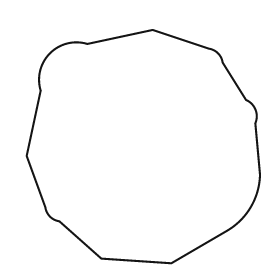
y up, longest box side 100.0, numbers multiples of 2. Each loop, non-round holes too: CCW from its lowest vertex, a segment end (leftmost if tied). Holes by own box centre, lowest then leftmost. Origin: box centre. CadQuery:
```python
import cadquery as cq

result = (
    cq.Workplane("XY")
    .moveTo(12.0, -50.0)
    .lineTo(36.0, -36.0)
    .threePointArc((46.0, -26.0), (50.0, -12.0))
    .lineTo(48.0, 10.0)
    .threePointArc((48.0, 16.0), (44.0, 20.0))
    .lineTo(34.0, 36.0)
    .threePointArc((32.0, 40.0), (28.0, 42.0))
    .lineTo(4.0, 50.0)
    .lineTo(-24.0, 44.0)
    .threePointArc((-40.0, 40.0), (-44.0, 24.0))
    .lineTo(-50.0, -4.0)
    .lineTo(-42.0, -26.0)
    .threePointArc((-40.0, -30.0), (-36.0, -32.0))
    .lineTo(-18.0, -48.0)
    .close()
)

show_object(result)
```